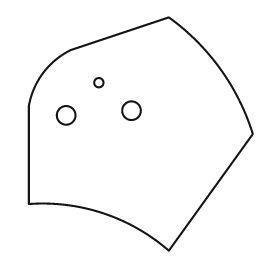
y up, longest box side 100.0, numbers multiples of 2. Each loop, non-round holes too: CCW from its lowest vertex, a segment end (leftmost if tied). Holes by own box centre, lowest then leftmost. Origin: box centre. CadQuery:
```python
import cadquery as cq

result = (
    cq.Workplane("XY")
    .moveTo(12.0, -50.0)
    .lineTo(48.0, 0.0)
    .threePointArc((34.0, 28.0), (12.0, 50.0))
    .lineTo(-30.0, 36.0)
    .threePointArc((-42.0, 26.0), (-48.0, 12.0))
    .lineTo(-48.0, -30.0)
    .threePointArc((-16.0, -34.0), (12.0, -50.0))
    .close()
    .moveTo(-32.0, 8.0)
    .circle(4.0)
    .moveTo(-4.0, 10.0)
    .circle(4.0)
    .moveTo(-18.0, 22.0)
    .circle(2.0)
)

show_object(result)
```